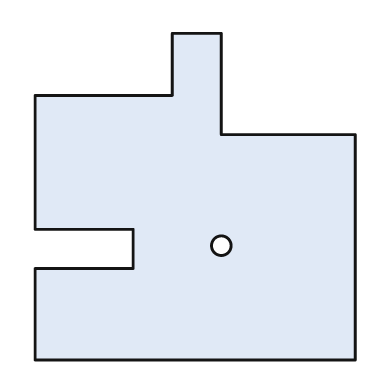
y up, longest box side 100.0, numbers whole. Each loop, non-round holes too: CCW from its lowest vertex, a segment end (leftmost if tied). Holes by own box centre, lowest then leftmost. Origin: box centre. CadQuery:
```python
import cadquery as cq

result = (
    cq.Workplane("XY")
    .moveTo(-49.0, -50.0)
    .lineTo(49.0, -50.0)
    .lineTo(49.0, 19.0)
    .lineTo(8.0, 19.0)
    .lineTo(8.0, 50.0)
    .lineTo(-7.0, 50.0)
    .lineTo(-7.0, 31.0)
    .lineTo(-49.0, 31.0)
    .lineTo(-49.0, -10.0)
    .lineTo(-19.0, -10.0)
    .lineTo(-19.0, -22.0)
    .lineTo(-49.0, -22.0)
    .close()
    .moveTo(8.0, -15.0)
    .circle(3.0)
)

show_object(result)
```